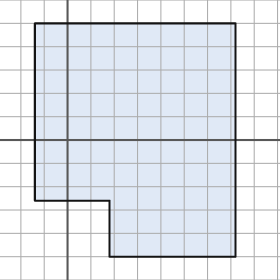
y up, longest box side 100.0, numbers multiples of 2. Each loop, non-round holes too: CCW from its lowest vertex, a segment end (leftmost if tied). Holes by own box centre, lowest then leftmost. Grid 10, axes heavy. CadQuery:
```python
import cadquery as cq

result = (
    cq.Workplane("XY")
    .moveTo(18.0, -50.0)
    .lineTo(72.0, -50.0)
    .lineTo(72.0, 50.0)
    .lineTo(-14.0, 50.0)
    .lineTo(-14.0, -26.0)
    .lineTo(18.0, -26.0)
    .close()
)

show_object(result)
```